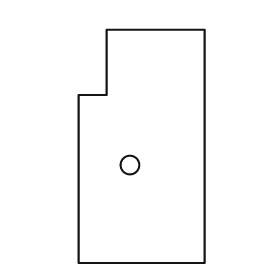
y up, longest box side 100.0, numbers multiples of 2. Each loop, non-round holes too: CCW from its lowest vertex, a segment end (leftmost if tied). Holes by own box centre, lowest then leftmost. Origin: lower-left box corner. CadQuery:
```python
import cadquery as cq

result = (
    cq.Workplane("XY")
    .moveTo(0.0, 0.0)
    .lineTo(54.0, 0.0)
    .lineTo(54.0, 100.0)
    .lineTo(12.0, 100.0)
    .lineTo(12.0, 72.0)
    .lineTo(0.0, 72.0)
    .close()
    .moveTo(22.0, 42.0)
    .circle(4.0)
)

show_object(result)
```